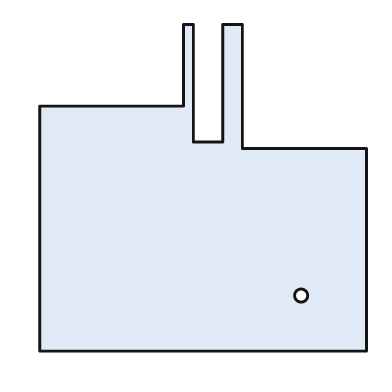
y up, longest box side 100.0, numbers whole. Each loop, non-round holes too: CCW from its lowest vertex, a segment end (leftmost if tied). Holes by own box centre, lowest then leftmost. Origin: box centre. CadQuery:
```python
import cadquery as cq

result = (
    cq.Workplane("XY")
    .moveTo(-50.0, -50.0)
    .lineTo(50.0, -50.0)
    .lineTo(50.0, 12.0)
    .lineTo(12.0, 12.0)
    .lineTo(12.0, 50.0)
    .lineTo(6.0, 50.0)
    .lineTo(6.0, 14.0)
    .lineTo(-3.0, 14.0)
    .lineTo(-3.0, 50.0)
    .lineTo(-6.0, 50.0)
    .lineTo(-6.0, 25.0)
    .lineTo(-50.0, 25.0)
    .close()
    .moveTo(30.0, -33.0)
    .circle(2.0)
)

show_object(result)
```